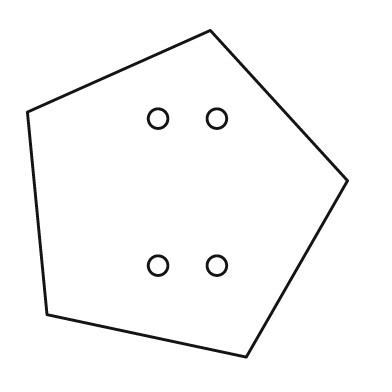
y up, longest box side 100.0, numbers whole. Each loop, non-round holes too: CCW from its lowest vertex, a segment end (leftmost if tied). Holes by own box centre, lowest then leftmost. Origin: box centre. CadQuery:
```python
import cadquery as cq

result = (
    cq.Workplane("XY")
    .moveTo(18.0, -50.0)
    .lineTo(49.0, 4.0)
    .lineTo(7.0, 50.0)
    .lineTo(-49.0, 25.0)
    .lineTo(-43.0, -37.0)
    .close()
    .moveTo(-9.0, -22.0)
    .circle(3.0)
    .moveTo(9.0, -22.0)
    .circle(3.0)
    .moveTo(-9.0, 23.0)
    .circle(3.0)
    .moveTo(9.0, 23.0)
    .circle(3.0)
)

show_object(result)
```